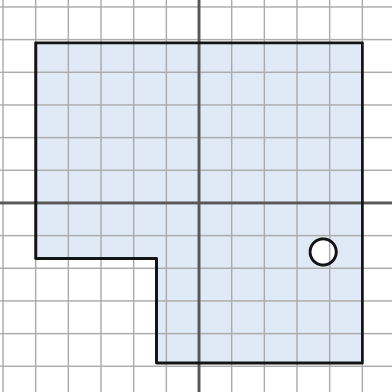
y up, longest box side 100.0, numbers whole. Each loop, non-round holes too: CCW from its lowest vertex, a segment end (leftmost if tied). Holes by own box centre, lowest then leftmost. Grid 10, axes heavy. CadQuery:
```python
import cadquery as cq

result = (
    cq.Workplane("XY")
    .moveTo(-13.0, -49.0)
    .lineTo(50.0, -49.0)
    .lineTo(50.0, 49.0)
    .lineTo(-50.0, 49.0)
    .lineTo(-50.0, -17.0)
    .lineTo(-13.0, -17.0)
    .close()
    .moveTo(38.0, -15.0)
    .circle(4.0)
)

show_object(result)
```